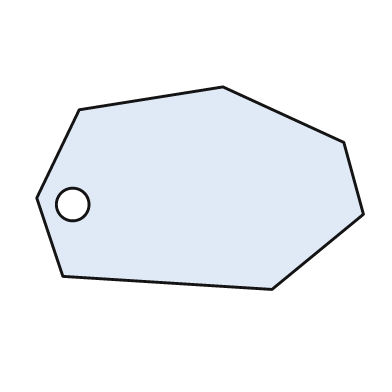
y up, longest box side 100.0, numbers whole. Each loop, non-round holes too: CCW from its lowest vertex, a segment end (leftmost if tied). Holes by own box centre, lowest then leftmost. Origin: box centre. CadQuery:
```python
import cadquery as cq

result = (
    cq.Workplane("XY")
    .moveTo(22.0, -31.0)
    .lineTo(50.0, -8.0)
    .lineTo(44.0, 14.0)
    .lineTo(7.0, 31.0)
    .lineTo(-37.0, 24.0)
    .lineTo(-50.0, -3.0)
    .lineTo(-42.0, -27.0)
    .close()
    .moveTo(-39.0, -5.0)
    .circle(5.0)
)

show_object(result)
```